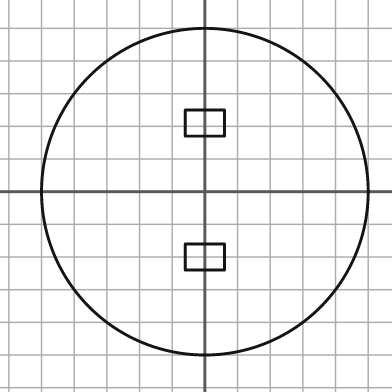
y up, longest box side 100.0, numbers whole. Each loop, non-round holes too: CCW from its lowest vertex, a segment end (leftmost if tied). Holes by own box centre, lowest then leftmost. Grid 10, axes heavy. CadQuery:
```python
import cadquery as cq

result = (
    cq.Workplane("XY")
    .moveTo(0.0, 0.0)
    .circle(50.0)
    .moveTo(-6.0, -24.0)
    .lineTo(6.0, -24.0)
    .lineTo(6.0, -16.0)
    .lineTo(-6.0, -16.0)
    .close()
    .moveTo(-6.0, 17.0)
    .lineTo(6.0, 17.0)
    .lineTo(6.0, 25.0)
    .lineTo(-6.0, 25.0)
    .close()
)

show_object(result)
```